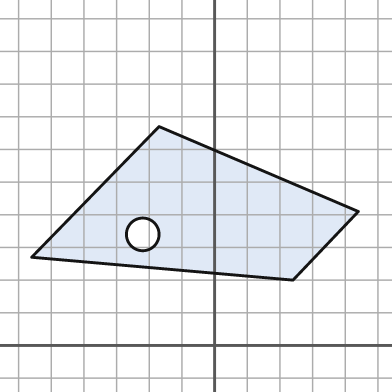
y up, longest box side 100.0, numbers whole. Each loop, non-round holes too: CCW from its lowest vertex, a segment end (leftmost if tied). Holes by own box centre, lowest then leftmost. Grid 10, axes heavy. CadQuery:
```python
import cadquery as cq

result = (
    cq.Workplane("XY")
    .moveTo(24.0, 20.0)
    .lineTo(44.0, 41.0)
    .lineTo(-17.0, 67.0)
    .lineTo(-56.0, 27.0)
    .close()
    .moveTo(-22.0, 34.0)
    .circle(5.0)
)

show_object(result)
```